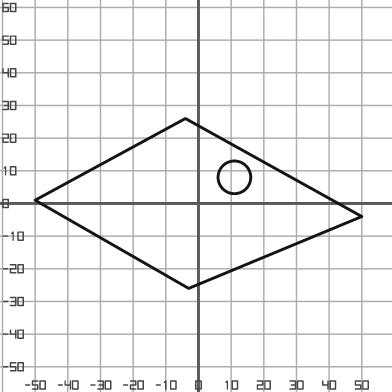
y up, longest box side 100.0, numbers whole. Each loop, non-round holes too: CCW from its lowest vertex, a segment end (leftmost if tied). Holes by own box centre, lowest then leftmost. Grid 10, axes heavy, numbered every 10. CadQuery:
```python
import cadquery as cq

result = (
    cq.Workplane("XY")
    .moveTo(-3.0, -26.0)
    .lineTo(50.0, -4.0)
    .lineTo(-4.0, 26.0)
    .lineTo(-50.0, 1.0)
    .close()
    .moveTo(11.0, 8.0)
    .circle(5.0)
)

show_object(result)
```